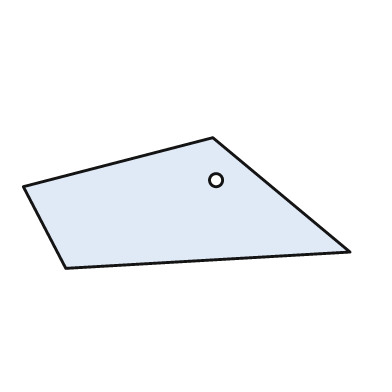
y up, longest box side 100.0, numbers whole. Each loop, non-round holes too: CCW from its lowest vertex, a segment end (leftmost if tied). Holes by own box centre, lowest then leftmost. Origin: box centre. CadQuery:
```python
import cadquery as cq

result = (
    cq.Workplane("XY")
    .moveTo(-37.0, -20.0)
    .lineTo(50.0, -15.0)
    .lineTo(8.0, 20.0)
    .lineTo(-50.0, 5.0)
    .close()
    .moveTo(9.0, 7.0)
    .circle(2.0)
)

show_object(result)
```